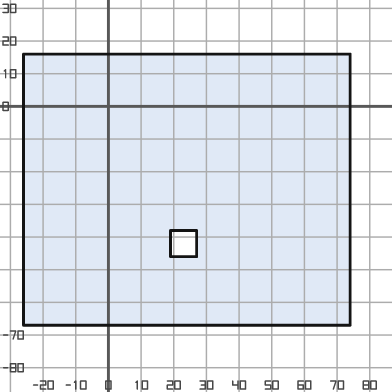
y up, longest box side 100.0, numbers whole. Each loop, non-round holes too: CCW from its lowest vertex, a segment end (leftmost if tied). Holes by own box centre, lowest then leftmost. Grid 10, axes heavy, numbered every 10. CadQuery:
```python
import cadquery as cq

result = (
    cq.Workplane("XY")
    .moveTo(-26.0, -67.0)
    .lineTo(74.0, -67.0)
    .lineTo(74.0, 16.0)
    .lineTo(-26.0, 16.0)
    .close()
    .moveTo(19.0, -46.0)
    .lineTo(27.0, -46.0)
    .lineTo(27.0, -38.0)
    .lineTo(19.0, -38.0)
    .close()
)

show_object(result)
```